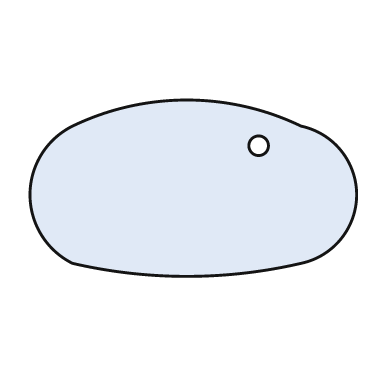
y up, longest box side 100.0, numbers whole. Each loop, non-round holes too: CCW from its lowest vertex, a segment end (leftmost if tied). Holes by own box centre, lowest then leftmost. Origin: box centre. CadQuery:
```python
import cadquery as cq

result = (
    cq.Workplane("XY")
    .moveTo(-37.0, -23.0)
    .threePointArc((-2.0, -27.0), (33.0, -23.0))
    .threePointArc((50.0, -2.0), (33.0, 19.0))
    .threePointArc((-2.0, 27.0), (-37.0, 19.0))
    .threePointArc((-50.0, -2.0), (-37.0, -23.0))
    .close()
    .moveTo(20.0, 13.0)
    .circle(3.0)
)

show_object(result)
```